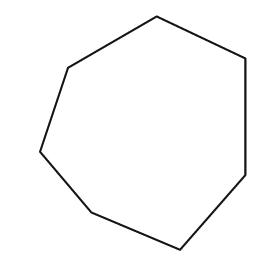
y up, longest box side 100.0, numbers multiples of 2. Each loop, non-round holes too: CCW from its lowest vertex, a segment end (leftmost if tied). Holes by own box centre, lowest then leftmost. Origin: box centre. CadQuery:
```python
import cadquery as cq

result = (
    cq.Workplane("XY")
    .moveTo(16.0, -50.0)
    .lineTo(44.0, -18.0)
    .lineTo(44.0, 32.0)
    .lineTo(6.0, 50.0)
    .lineTo(-32.0, 28.0)
    .lineTo(-44.0, -8.0)
    .lineTo(-22.0, -34.0)
    .close()
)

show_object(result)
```